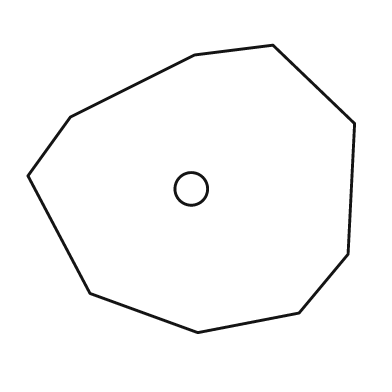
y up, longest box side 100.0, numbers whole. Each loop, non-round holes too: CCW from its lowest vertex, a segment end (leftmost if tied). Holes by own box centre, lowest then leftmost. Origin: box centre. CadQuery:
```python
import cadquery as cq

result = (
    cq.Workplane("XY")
    .moveTo(2.0, -44.0)
    .lineTo(33.0, -38.0)
    .lineTo(48.0, -20.0)
    .lineTo(50.0, 20.0)
    .lineTo(25.0, 44.0)
    .lineTo(1.0, 41.0)
    .lineTo(-37.0, 22.0)
    .lineTo(-50.0, 4.0)
    .lineTo(-31.0, -32.0)
    .close()
    .moveTo(0.0, 0.0)
    .circle(5.0)
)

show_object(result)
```